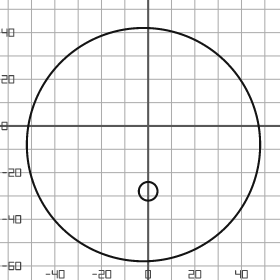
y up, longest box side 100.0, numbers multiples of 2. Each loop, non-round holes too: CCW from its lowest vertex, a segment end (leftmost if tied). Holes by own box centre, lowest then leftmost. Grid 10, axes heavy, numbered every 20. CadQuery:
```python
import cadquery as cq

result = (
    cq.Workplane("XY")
    .moveTo(-2.0, -8.0)
    .circle(50.0)
    .moveTo(0.0, -28.0)
    .circle(4.0)
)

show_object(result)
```